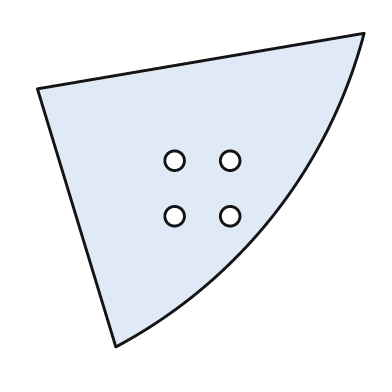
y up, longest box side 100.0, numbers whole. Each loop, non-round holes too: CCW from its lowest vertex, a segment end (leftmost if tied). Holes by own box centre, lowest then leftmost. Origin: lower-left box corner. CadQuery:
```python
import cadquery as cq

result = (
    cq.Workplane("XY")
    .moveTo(24.0, 0.0)
    .threePointArc((72.0, 40.0), (100.0, 96.0))
    .lineTo(0.0, 79.0)
    .close()
    .moveTo(42.0, 40.0)
    .circle(3.0)
    .moveTo(59.0, 40.0)
    .circle(3.0)
    .moveTo(42.0, 57.0)
    .circle(3.0)
    .moveTo(59.0, 57.0)
    .circle(3.0)
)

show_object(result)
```